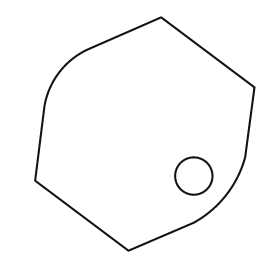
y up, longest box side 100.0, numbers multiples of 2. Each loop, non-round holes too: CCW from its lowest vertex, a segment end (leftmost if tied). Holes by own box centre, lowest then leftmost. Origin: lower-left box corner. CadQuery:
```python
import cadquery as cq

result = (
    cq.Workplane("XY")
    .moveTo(40.0, 0.0)
    .lineTo(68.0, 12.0)
    .threePointArc((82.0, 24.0), (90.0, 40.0))
    .lineTo(94.0, 70.0)
    .lineTo(54.0, 100.0)
    .lineTo(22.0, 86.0)
    .threePointArc((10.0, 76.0), (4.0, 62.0))
    .lineTo(0.0, 30.0)
    .close()
    .moveTo(68.0, 32.0)
    .circle(8.0)
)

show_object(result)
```